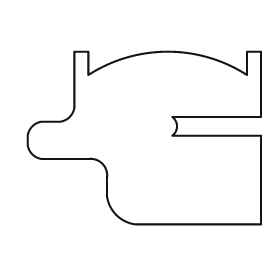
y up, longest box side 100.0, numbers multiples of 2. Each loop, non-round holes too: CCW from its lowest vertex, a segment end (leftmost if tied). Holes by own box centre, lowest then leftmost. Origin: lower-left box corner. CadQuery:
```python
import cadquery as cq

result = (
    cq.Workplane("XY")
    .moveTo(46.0, 0.0)
    .lineTo(100.0, 0.0)
    .lineTo(100.0, 38.0)
    .lineTo(62.0, 38.0)
    .threePointArc((64.0, 42.0), (62.0, 46.0))
    .lineTo(100.0, 46.0)
    .lineTo(100.0, 74.0)
    .lineTo(94.0, 74.0)
    .lineTo(94.0, 64.0)
    .threePointArc((60.0, 74.0), (26.0, 64.0))
    .lineTo(26.0, 74.0)
    .lineTo(20.0, 74.0)
    .lineTo(20.0, 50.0)
    .threePointArc((18.0, 46.0), (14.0, 44.0))
    .lineTo(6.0, 44.0)
    .threePointArc((2.0, 42.0), (0.0, 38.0))
    .lineTo(0.0, 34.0)
    .threePointArc((2.0, 30.0), (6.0, 28.0))
    .lineTo(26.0, 28.0)
    .threePointArc((32.0, 26.0), (34.0, 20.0))
    .lineTo(34.0, 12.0)
    .threePointArc((38.0, 4.0), (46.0, 0.0))
    .close()
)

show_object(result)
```